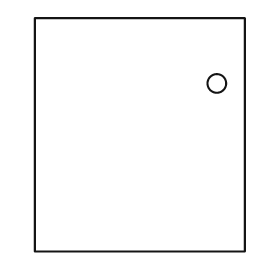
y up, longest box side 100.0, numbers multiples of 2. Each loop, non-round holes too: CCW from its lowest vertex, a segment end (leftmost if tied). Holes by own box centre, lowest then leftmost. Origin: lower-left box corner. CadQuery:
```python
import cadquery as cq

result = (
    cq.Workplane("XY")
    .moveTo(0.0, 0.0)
    .lineTo(90.0, 0.0)
    .lineTo(90.0, 100.0)
    .lineTo(0.0, 100.0)
    .close()
    .moveTo(78.0, 72.0)
    .circle(4.0)
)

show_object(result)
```